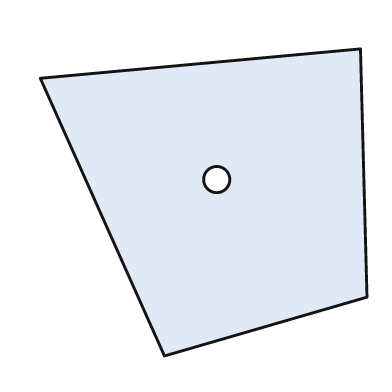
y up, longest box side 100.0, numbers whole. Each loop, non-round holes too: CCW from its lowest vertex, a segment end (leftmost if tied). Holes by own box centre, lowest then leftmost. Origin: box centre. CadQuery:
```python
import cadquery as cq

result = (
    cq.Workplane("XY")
    .moveTo(-12.0, -47.0)
    .lineTo(50.0, -29.0)
    .lineTo(48.0, 47.0)
    .lineTo(-50.0, 38.0)
    .close()
    .moveTo(4.0, 7.0)
    .circle(4.0)
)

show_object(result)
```